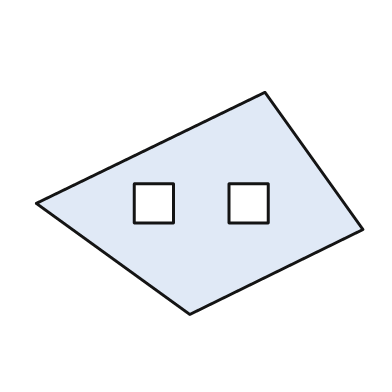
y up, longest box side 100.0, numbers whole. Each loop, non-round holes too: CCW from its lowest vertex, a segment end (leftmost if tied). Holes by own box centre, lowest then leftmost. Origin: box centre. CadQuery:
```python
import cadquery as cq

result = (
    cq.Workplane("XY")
    .moveTo(-3.0, -34.0)
    .lineTo(50.0, -8.0)
    .lineTo(20.0, 34.0)
    .lineTo(-50.0, 0.0)
    .close()
    .moveTo(-20.0, -6.0)
    .lineTo(-8.0, -6.0)
    .lineTo(-8.0, 6.0)
    .lineTo(-20.0, 6.0)
    .close()
    .moveTo(9.0, -6.0)
    .lineTo(21.0, -6.0)
    .lineTo(21.0, 6.0)
    .lineTo(9.0, 6.0)
    .close()
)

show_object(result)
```